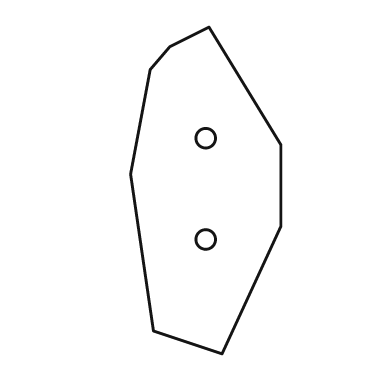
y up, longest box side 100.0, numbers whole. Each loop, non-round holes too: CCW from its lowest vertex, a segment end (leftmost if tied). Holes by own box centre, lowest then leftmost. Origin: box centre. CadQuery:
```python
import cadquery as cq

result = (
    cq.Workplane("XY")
    .moveTo(5.0, -50.0)
    .lineTo(23.0, -11.0)
    .lineTo(23.0, 14.0)
    .lineTo(1.0, 50.0)
    .lineTo(-11.0, 44.0)
    .lineTo(-17.0, 37.0)
    .lineTo(-23.0, 5.0)
    .lineTo(-16.0, -43.0)
    .close()
    .moveTo(0.0, -15.0)
    .circle(3.0)
    .moveTo(0.0, 16.0)
    .circle(3.0)
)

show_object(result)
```